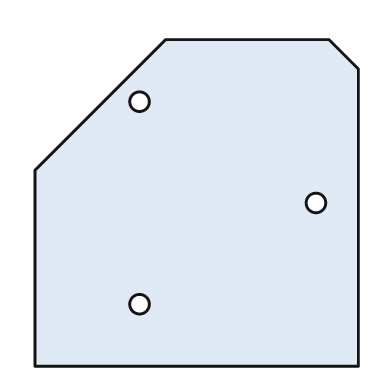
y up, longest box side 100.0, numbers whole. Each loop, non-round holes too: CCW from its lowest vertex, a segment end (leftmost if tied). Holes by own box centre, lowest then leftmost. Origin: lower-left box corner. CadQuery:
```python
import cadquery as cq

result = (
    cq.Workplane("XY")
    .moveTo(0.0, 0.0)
    .lineTo(99.0, 0.0)
    .lineTo(99.0, 91.0)
    .lineTo(90.0, 100.0)
    .lineTo(40.0, 100.0)
    .lineTo(0.0, 60.0)
    .close()
    .moveTo(32.0, 19.0)
    .circle(3.0)
    .moveTo(86.0, 50.0)
    .circle(3.0)
    .moveTo(32.0, 81.0)
    .circle(3.0)
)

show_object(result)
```